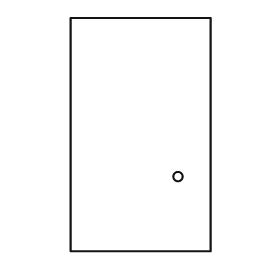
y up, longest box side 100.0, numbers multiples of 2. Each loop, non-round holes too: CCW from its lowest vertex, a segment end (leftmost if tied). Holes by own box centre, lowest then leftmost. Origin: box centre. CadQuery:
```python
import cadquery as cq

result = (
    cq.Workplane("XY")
    .moveTo(-30.0, -50.0)
    .lineTo(30.0, -50.0)
    .lineTo(30.0, 50.0)
    .lineTo(-30.0, 50.0)
    .close()
    .moveTo(16.0, -18.0)
    .circle(2.0)
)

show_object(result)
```